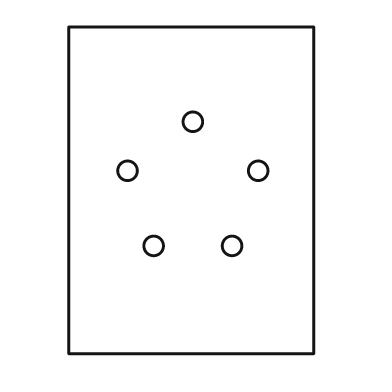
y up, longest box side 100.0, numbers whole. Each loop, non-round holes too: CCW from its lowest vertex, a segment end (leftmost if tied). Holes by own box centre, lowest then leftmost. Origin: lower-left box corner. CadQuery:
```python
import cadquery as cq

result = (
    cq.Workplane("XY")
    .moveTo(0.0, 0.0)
    .lineTo(75.0, 0.0)
    .lineTo(75.0, 100.0)
    .lineTo(0.0, 100.0)
    .close()
    .moveTo(26.0, 33.0)
    .circle(3.0)
    .moveTo(50.0, 33.0)
    .circle(3.0)
    .moveTo(18.0, 56.0)
    .circle(3.0)
    .moveTo(58.0, 56.0)
    .circle(3.0)
    .moveTo(38.0, 71.0)
    .circle(3.0)
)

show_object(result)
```